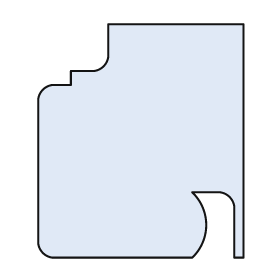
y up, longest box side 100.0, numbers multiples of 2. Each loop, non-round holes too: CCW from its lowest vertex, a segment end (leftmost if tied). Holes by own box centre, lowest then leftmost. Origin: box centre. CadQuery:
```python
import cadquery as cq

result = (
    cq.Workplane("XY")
    .moveTo(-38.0, -50.0)
    .lineTo(22.0, -50.0)
    .threePointArc((28.0, -36.0), (22.0, -22.0))
    .lineTo(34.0, -22.0)
    .threePointArc((38.0, -24.0), (40.0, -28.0))
    .lineTo(40.0, -50.0)
    .lineTo(44.0, -50.0)
    .lineTo(44.0, 50.0)
    .lineTo(-14.0, 50.0)
    .lineTo(-14.0, 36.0)
    .threePointArc((-16.0, 32.0), (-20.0, 30.0))
    .lineTo(-30.0, 30.0)
    .lineTo(-30.0, 24.0)
    .lineTo(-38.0, 24.0)
    .threePointArc((-42.0, 22.0), (-44.0, 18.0))
    .lineTo(-44.0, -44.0)
    .threePointArc((-42.0, -48.0), (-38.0, -50.0))
    .close()
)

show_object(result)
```